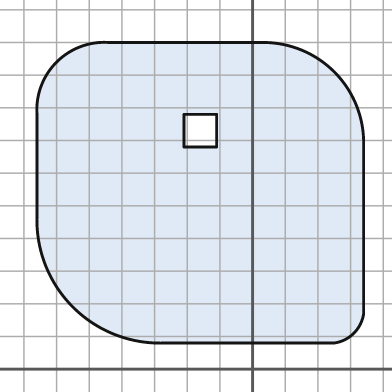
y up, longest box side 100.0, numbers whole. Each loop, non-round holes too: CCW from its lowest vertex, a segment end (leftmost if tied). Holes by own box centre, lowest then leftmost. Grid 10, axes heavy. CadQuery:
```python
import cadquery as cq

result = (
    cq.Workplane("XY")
    .moveTo(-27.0, 8.0)
    .lineTo(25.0, 8.0)
    .threePointArc((31.0, 11.0), (34.0, 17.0))
    .lineTo(34.0, 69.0)
    .threePointArc((25.0, 91.0), (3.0, 100.0))
    .lineTo(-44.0, 100.0)
    .threePointArc((-60.0, 94.0), (-66.0, 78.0))
    .lineTo(-66.0, 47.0)
    .threePointArc((-55.0, 19.0), (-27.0, 8.0))
    .close()
    .moveTo(-21.0, 68.0)
    .lineTo(-11.0, 68.0)
    .lineTo(-11.0, 78.0)
    .lineTo(-21.0, 78.0)
    .close()
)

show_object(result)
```